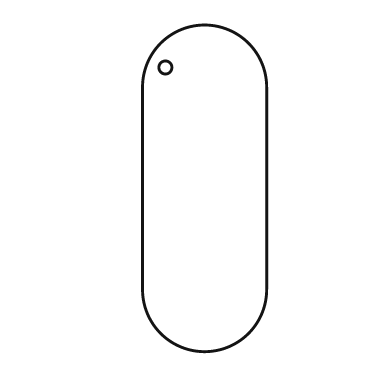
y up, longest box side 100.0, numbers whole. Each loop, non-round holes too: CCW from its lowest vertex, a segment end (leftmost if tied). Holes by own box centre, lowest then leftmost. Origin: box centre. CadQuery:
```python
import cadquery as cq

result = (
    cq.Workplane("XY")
    .moveTo(-19.0, -31.0)
    .threePointArc((0.0, -50.0), (19.0, -31.0))
    .lineTo(19.0, 31.0)
    .threePointArc((0.0, 50.0), (-19.0, 31.0))
    .close()
    .moveTo(-12.0, 37.0)
    .circle(2.0)
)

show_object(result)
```